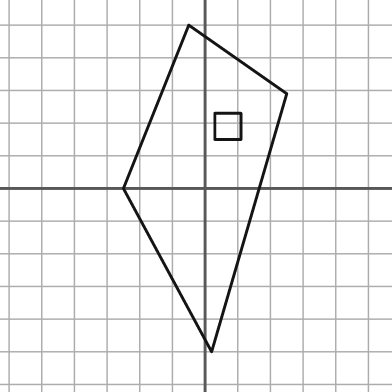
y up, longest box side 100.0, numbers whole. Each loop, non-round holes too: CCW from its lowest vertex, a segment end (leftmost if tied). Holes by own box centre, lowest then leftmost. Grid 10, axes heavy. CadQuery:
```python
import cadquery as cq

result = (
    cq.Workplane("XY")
    .moveTo(2.0, -50.0)
    .lineTo(25.0, 29.0)
    .lineTo(-5.0, 50.0)
    .lineTo(-25.0, 0.0)
    .close()
    .moveTo(3.0, 15.0)
    .lineTo(11.0, 15.0)
    .lineTo(11.0, 23.0)
    .lineTo(3.0, 23.0)
    .close()
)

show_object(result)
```